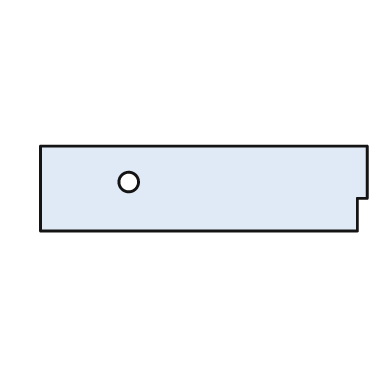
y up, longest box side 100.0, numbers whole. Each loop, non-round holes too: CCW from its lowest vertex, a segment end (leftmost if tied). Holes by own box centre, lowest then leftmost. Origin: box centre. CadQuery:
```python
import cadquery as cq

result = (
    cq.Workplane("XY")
    .moveTo(-50.0, -13.0)
    .lineTo(47.0, -13.0)
    .lineTo(47.0, -3.0)
    .lineTo(50.0, -3.0)
    .lineTo(50.0, 13.0)
    .lineTo(-50.0, 13.0)
    .close()
    .moveTo(-23.0, 2.0)
    .circle(3.0)
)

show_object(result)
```